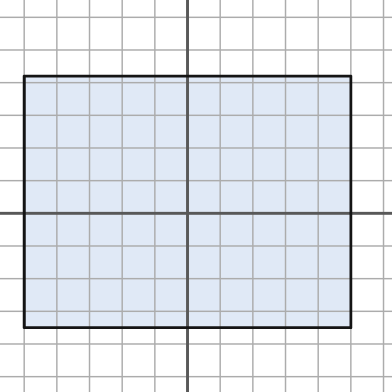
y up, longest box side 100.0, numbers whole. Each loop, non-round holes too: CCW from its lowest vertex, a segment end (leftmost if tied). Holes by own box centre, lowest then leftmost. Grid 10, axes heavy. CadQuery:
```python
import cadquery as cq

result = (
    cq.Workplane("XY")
    .moveTo(-50.0, -35.0)
    .lineTo(50.0, -35.0)
    .lineTo(50.0, 42.0)
    .lineTo(-50.0, 42.0)
    .close()
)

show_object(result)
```